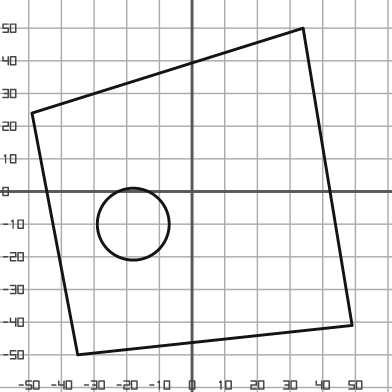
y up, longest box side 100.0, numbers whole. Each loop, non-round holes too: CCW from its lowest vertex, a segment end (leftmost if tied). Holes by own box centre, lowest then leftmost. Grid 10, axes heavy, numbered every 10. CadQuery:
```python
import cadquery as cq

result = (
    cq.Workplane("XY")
    .moveTo(-35.0, -50.0)
    .lineTo(49.0, -41.0)
    .lineTo(34.0, 50.0)
    .lineTo(-49.0, 24.0)
    .close()
    .moveTo(-18.0, -10.0)
    .circle(11.0)
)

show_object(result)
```